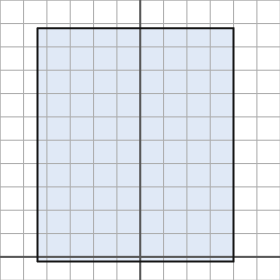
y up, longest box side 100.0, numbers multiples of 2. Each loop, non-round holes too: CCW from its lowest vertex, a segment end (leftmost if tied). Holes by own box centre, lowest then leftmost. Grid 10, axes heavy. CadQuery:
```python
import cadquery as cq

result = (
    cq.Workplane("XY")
    .moveTo(-44.0, -2.0)
    .lineTo(40.0, -2.0)
    .lineTo(40.0, 98.0)
    .lineTo(-44.0, 98.0)
    .close()
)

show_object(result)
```